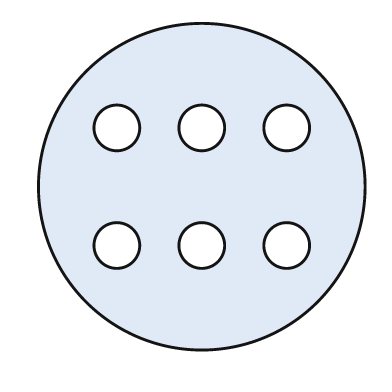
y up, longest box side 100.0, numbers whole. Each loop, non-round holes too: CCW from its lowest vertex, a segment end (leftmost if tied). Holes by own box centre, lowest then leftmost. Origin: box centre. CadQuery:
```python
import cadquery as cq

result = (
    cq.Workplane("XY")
    .moveTo(0.0, 0.0)
    .circle(50.0)
    .moveTo(-26.0, -18.0)
    .circle(7.0)
    .moveTo(0.0, -18.0)
    .circle(7.0)
    .moveTo(26.0, -18.0)
    .circle(7.0)
    .moveTo(-26.0, 18.0)
    .circle(7.0)
    .moveTo(0.0, 18.0)
    .circle(7.0)
    .moveTo(26.0, 18.0)
    .circle(7.0)
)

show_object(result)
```